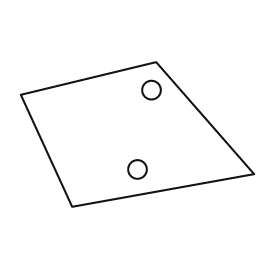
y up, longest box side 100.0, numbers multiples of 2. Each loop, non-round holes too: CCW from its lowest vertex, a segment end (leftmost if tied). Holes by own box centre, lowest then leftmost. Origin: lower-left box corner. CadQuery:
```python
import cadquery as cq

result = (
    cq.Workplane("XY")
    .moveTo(22.0, 0.0)
    .lineTo(100.0, 14.0)
    .lineTo(58.0, 62.0)
    .lineTo(0.0, 48.0)
    .close()
    .moveTo(50.0, 16.0)
    .circle(4.0)
    .moveTo(56.0, 50.0)
    .circle(4.0)
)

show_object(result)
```